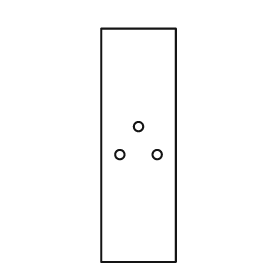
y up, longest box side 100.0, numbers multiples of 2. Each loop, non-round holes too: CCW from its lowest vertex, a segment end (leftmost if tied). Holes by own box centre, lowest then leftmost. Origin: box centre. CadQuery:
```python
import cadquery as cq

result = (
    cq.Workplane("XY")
    .moveTo(-16.0, -50.0)
    .lineTo(16.0, -50.0)
    .lineTo(16.0, 50.0)
    .lineTo(-16.0, 50.0)
    .close()
    .moveTo(-8.0, -4.0)
    .circle(2.0)
    .moveTo(8.0, -4.0)
    .circle(2.0)
    .moveTo(0.0, 8.0)
    .circle(2.0)
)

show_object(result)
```